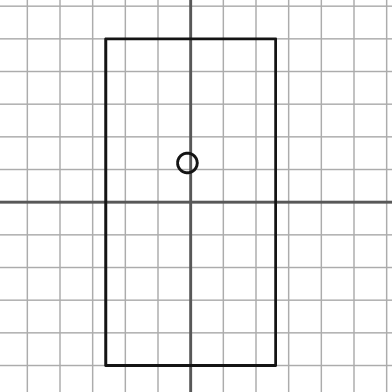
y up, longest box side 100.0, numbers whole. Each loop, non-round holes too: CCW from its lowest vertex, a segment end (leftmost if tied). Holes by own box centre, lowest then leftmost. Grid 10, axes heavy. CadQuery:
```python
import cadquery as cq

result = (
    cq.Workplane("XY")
    .moveTo(-26.0, -50.0)
    .lineTo(26.0, -50.0)
    .lineTo(26.0, 50.0)
    .lineTo(-26.0, 50.0)
    .close()
    .moveTo(-1.0, 12.0)
    .circle(3.0)
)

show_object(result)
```